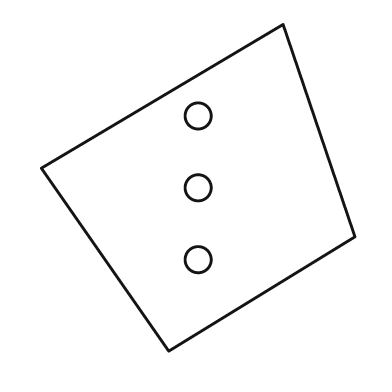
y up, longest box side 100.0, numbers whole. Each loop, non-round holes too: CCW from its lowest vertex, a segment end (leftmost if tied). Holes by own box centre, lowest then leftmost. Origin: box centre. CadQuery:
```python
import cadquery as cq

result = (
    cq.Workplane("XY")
    .moveTo(-9.0, -50.0)
    .lineTo(48.0, -15.0)
    .lineTo(26.0, 50.0)
    .lineTo(-48.0, 6.0)
    .close()
    .moveTo(0.0, -22.0)
    .circle(4.0)
    .moveTo(0.0, 0.0)
    .circle(4.0)
    .moveTo(0.0, 22.0)
    .circle(4.0)
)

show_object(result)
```